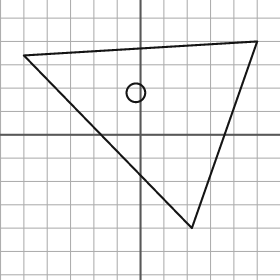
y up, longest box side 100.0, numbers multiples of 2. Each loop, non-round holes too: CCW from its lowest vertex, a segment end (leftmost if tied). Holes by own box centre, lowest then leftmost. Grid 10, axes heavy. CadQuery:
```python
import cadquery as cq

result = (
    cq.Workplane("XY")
    .moveTo(22.0, -40.0)
    .lineTo(50.0, 40.0)
    .lineTo(-50.0, 34.0)
    .close()
    .moveTo(-2.0, 18.0)
    .circle(4.0)
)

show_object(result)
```